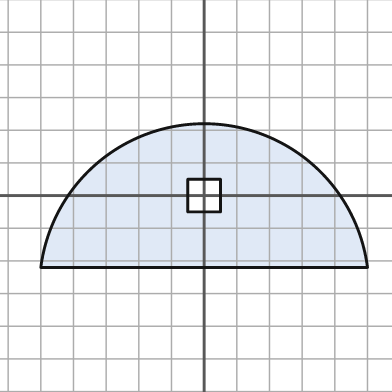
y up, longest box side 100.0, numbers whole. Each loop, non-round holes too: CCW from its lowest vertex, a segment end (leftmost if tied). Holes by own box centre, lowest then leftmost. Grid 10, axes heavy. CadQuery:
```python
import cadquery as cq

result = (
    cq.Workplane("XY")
    .moveTo(-50.0, -22.0)
    .lineTo(50.0, -22.0)
    .threePointArc((0.0, 22.0), (-50.0, -22.0))
    .close()
    .moveTo(-5.0, -5.0)
    .lineTo(5.0, -5.0)
    .lineTo(5.0, 5.0)
    .lineTo(-5.0, 5.0)
    .close()
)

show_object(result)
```